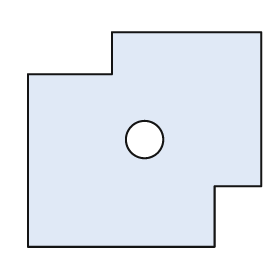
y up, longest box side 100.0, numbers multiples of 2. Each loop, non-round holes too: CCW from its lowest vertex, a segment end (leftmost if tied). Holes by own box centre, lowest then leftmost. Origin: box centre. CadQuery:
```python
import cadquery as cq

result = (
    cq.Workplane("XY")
    .moveTo(-50.0, -46.0)
    .lineTo(30.0, -46.0)
    .lineTo(30.0, -20.0)
    .lineTo(50.0, -20.0)
    .lineTo(50.0, 46.0)
    .lineTo(-14.0, 46.0)
    .lineTo(-14.0, 28.0)
    .lineTo(-50.0, 28.0)
    .close()
    .moveTo(0.0, 0.0)
    .circle(8.0)
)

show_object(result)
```